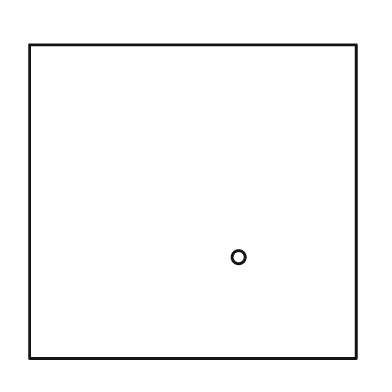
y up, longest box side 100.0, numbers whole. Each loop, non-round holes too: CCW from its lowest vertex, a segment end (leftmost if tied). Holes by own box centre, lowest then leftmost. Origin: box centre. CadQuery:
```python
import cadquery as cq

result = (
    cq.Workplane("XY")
    .moveTo(-50.0, -48.0)
    .lineTo(50.0, -48.0)
    .lineTo(50.0, 48.0)
    .lineTo(-50.0, 48.0)
    .close()
    .moveTo(14.0, -17.0)
    .circle(2.0)
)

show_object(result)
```